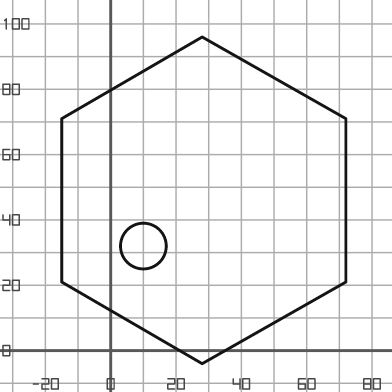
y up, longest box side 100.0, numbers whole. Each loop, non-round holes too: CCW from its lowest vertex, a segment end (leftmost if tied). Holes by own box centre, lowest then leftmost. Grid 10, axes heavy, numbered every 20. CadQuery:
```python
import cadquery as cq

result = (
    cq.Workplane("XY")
    .moveTo(28.0, -4.0)
    .lineTo(72.0, 21.0)
    .lineTo(72.0, 71.0)
    .lineTo(28.0, 96.0)
    .lineTo(-15.0, 71.0)
    .lineTo(-15.0, 21.0)
    .close()
    .moveTo(10.0, 32.0)
    .circle(7.0)
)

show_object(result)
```